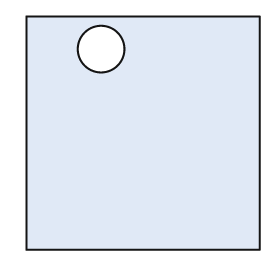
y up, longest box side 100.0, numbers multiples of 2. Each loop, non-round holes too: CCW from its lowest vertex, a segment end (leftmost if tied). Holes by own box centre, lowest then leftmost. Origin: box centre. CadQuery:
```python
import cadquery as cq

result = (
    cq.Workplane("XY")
    .moveTo(-50.0, -50.0)
    .lineTo(50.0, -50.0)
    .lineTo(50.0, 50.0)
    .lineTo(-50.0, 50.0)
    .close()
    .moveTo(-18.0, 36.0)
    .circle(10.0)
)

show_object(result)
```